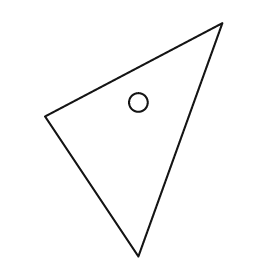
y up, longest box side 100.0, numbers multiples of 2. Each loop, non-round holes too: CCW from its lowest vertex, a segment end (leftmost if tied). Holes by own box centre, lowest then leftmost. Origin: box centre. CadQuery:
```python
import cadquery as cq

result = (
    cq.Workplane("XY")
    .moveTo(2.0, -50.0)
    .lineTo(38.0, 50.0)
    .lineTo(-38.0, 10.0)
    .close()
    .moveTo(2.0, 16.0)
    .circle(4.0)
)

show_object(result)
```